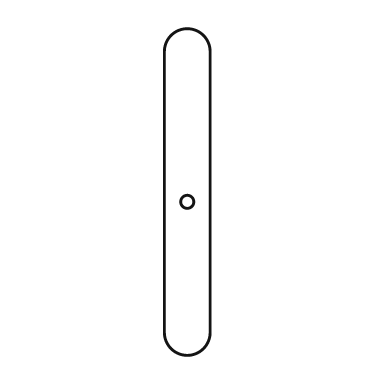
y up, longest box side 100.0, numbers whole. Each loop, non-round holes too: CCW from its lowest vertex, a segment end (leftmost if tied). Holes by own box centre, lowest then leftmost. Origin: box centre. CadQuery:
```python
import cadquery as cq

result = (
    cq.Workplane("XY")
    .moveTo(-7.0, -43.0)
    .threePointArc((0.0, -50.0), (7.0, -43.0))
    .lineTo(7.0, 43.0)
    .threePointArc((0.0, 50.0), (-7.0, 43.0))
    .close()
    .moveTo(0.0, -3.0)
    .circle(2.0)
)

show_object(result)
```